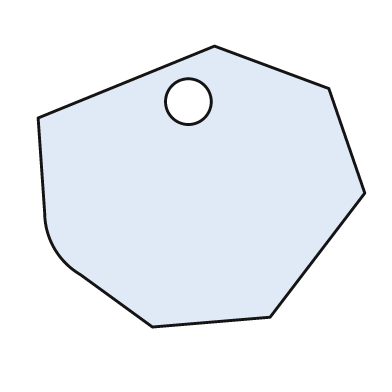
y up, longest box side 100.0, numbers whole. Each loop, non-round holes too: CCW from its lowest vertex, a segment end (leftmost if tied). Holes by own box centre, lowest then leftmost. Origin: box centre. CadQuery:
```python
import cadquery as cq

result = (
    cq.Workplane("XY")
    .moveTo(-15.0, -43.0)
    .lineTo(21.0, -40.0)
    .lineTo(50.0, -2.0)
    .lineTo(39.0, 30.0)
    .lineTo(4.0, 43.0)
    .lineTo(-50.0, 21.0)
    .lineTo(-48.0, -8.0)
    .threePointArc((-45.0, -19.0), (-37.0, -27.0))
    .close()
    .moveTo(-4.0, 26.0)
    .circle(7.0)
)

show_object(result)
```